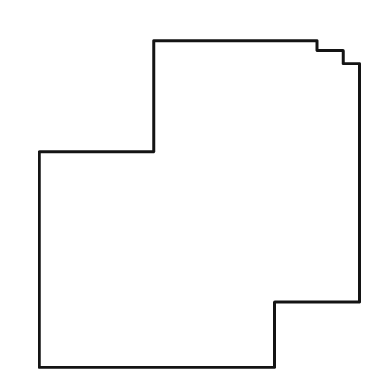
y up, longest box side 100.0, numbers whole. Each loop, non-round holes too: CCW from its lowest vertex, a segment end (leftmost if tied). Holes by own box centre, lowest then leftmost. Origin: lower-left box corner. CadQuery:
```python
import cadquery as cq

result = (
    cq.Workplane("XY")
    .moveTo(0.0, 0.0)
    .lineTo(72.0, 0.0)
    .lineTo(72.0, 20.0)
    .lineTo(98.0, 20.0)
    .lineTo(98.0, 93.0)
    .lineTo(93.0, 93.0)
    .lineTo(93.0, 97.0)
    .lineTo(85.0, 97.0)
    .lineTo(85.0, 100.0)
    .lineTo(35.0, 100.0)
    .lineTo(35.0, 66.0)
    .lineTo(0.0, 66.0)
    .close()
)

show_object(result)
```